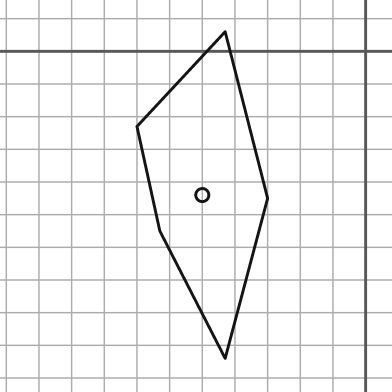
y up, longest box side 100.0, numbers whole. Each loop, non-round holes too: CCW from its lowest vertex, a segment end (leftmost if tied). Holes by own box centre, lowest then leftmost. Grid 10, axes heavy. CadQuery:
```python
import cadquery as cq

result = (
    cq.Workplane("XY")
    .moveTo(-43.0, -94.0)
    .lineTo(-30.0, -45.0)
    .lineTo(-43.0, 6.0)
    .lineTo(-70.0, -23.0)
    .lineTo(-63.0, -55.0)
    .close()
    .moveTo(-50.0, -44.0)
    .circle(2.0)
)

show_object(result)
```